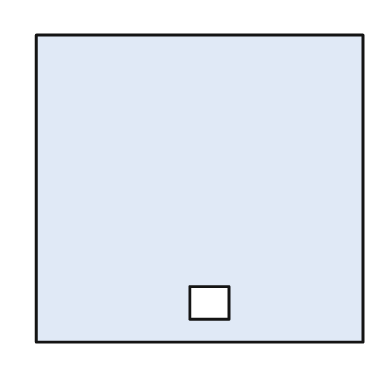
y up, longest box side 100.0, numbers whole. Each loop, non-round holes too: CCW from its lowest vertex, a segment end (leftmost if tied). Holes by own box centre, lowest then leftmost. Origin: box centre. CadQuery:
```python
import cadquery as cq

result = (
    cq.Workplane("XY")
    .moveTo(-50.0, -47.0)
    .lineTo(50.0, -47.0)
    .lineTo(50.0, 47.0)
    .lineTo(-50.0, 47.0)
    .close()
    .moveTo(-3.0, -40.0)
    .lineTo(9.0, -40.0)
    .lineTo(9.0, -30.0)
    .lineTo(-3.0, -30.0)
    .close()
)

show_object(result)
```